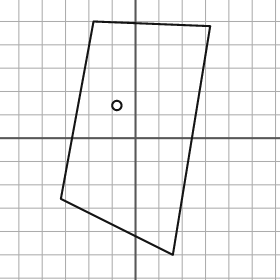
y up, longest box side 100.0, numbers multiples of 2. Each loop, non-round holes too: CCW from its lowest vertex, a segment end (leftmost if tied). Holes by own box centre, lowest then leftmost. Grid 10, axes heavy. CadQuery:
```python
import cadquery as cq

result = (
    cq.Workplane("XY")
    .moveTo(16.0, -50.0)
    .lineTo(32.0, 48.0)
    .lineTo(-18.0, 50.0)
    .lineTo(-32.0, -26.0)
    .close()
    .moveTo(-8.0, 14.0)
    .circle(2.0)
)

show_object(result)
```